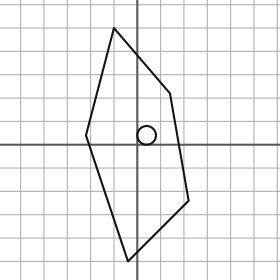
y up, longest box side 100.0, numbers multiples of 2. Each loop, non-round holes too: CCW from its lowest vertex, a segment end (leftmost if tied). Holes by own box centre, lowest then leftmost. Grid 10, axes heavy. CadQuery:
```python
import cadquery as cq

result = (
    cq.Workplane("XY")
    .moveTo(-4.0, -50.0)
    .lineTo(22.0, -24.0)
    .lineTo(14.0, 22.0)
    .lineTo(-10.0, 50.0)
    .lineTo(-22.0, 4.0)
    .close()
    .moveTo(4.0, 4.0)
    .circle(4.0)
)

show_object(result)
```